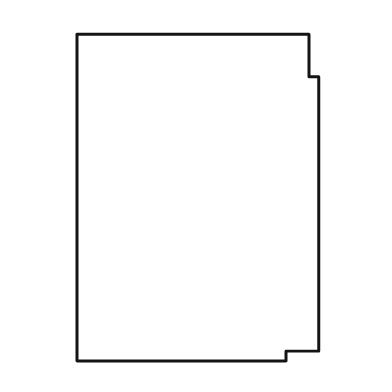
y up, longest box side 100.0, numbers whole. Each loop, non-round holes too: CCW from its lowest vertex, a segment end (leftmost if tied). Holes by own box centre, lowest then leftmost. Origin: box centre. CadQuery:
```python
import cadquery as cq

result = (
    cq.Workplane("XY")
    .moveTo(-37.0, -50.0)
    .lineTo(27.0, -50.0)
    .lineTo(27.0, -47.0)
    .lineTo(37.0, -47.0)
    .lineTo(37.0, 37.0)
    .lineTo(34.0, 37.0)
    .lineTo(34.0, 50.0)
    .lineTo(-37.0, 50.0)
    .close()
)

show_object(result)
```